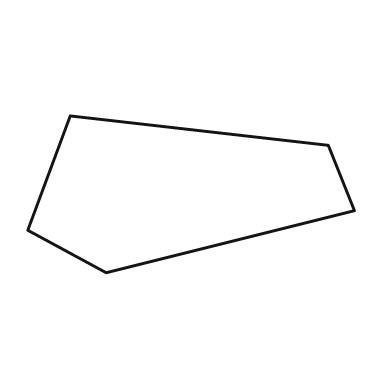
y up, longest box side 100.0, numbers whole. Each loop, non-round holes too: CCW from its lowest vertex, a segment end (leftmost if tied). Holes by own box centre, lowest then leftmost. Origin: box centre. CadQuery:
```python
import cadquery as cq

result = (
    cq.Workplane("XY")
    .moveTo(-26.0, -24.0)
    .lineTo(50.0, -5.0)
    .lineTo(42.0, 15.0)
    .lineTo(-37.0, 24.0)
    .lineTo(-50.0, -11.0)
    .close()
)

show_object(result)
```